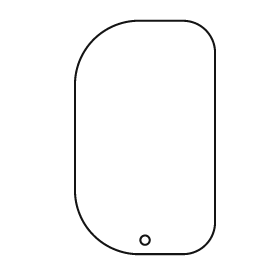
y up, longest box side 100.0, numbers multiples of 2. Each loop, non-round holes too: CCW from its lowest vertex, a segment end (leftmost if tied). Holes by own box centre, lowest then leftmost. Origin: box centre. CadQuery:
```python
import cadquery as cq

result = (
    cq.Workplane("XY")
    .moveTo(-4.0, -50.0)
    .lineTo(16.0, -50.0)
    .threePointArc((26.0, -46.0), (30.0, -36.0))
    .lineTo(30.0, 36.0)
    .threePointArc((26.0, 46.0), (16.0, 50.0))
    .lineTo(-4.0, 50.0)
    .threePointArc((-22.0, 42.0), (-30.0, 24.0))
    .lineTo(-30.0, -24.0)
    .threePointArc((-22.0, -42.0), (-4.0, -50.0))
    .close()
    .moveTo(0.0, -44.0)
    .circle(2.0)
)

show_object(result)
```